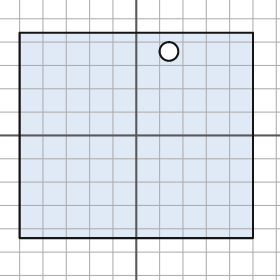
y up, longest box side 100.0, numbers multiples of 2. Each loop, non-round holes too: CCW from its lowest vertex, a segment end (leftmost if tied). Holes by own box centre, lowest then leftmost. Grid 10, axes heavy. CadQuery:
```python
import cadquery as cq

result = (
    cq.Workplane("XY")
    .moveTo(-50.0, -44.0)
    .lineTo(50.0, -44.0)
    .lineTo(50.0, 44.0)
    .lineTo(-50.0, 44.0)
    .close()
    .moveTo(14.0, 36.0)
    .circle(4.0)
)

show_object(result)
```